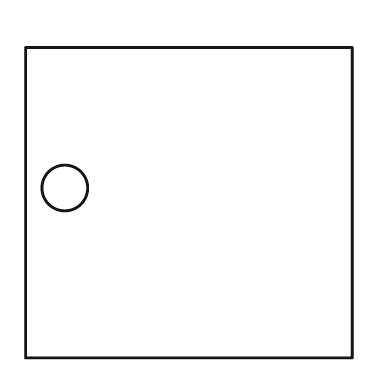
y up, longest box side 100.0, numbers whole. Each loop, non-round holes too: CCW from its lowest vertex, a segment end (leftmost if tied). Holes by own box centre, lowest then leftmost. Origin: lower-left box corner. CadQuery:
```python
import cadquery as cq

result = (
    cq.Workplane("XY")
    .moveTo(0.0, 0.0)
    .lineTo(100.0, 0.0)
    .lineTo(100.0, 95.0)
    .lineTo(0.0, 95.0)
    .close()
    .moveTo(12.0, 52.0)
    .circle(7.0)
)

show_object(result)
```